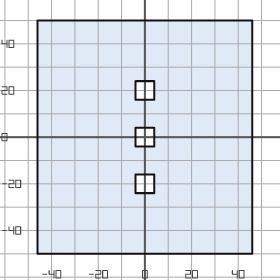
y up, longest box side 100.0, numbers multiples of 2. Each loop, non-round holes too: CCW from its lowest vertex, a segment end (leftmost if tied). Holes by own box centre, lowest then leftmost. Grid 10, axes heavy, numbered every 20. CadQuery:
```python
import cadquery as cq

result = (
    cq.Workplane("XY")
    .moveTo(-46.0, -50.0)
    .lineTo(46.0, -50.0)
    .lineTo(46.0, 50.0)
    .lineTo(-46.0, 50.0)
    .close()
    .moveTo(-4.0, -24.0)
    .lineTo(4.0, -24.0)
    .lineTo(4.0, -16.0)
    .lineTo(-4.0, -16.0)
    .close()
    .moveTo(-4.0, -4.0)
    .lineTo(4.0, -4.0)
    .lineTo(4.0, 4.0)
    .lineTo(-4.0, 4.0)
    .close()
    .moveTo(-4.0, 16.0)
    .lineTo(4.0, 16.0)
    .lineTo(4.0, 24.0)
    .lineTo(-4.0, 24.0)
    .close()
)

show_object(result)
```